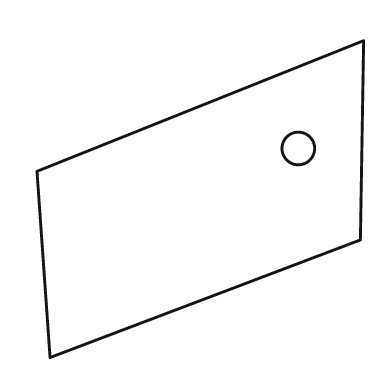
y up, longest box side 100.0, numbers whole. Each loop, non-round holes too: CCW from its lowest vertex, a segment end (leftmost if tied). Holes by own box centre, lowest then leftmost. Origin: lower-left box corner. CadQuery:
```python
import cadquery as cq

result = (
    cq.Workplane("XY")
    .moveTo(4.0, 0.0)
    .lineTo(99.0, 36.0)
    .lineTo(100.0, 97.0)
    .lineTo(0.0, 57.0)
    .close()
    .moveTo(80.0, 64.0)
    .circle(5.0)
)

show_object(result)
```